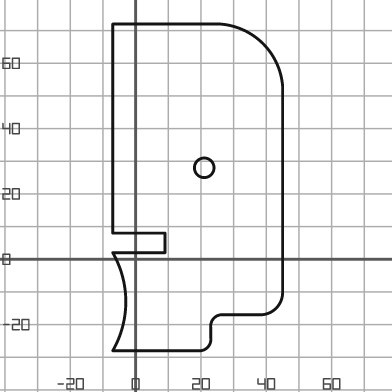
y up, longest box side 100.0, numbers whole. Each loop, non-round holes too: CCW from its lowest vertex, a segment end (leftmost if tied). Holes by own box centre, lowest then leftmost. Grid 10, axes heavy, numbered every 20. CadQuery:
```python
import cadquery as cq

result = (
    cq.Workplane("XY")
    .moveTo(-7.0, -28.0)
    .lineTo(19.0, -28.0)
    .threePointArc((22.0, -27.0), (23.0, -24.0))
    .lineTo(23.0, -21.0)
    .threePointArc((24.0, -18.0), (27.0, -17.0))
    .lineTo(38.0, -17.0)
    .threePointArc((43.0, -15.0), (45.0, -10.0))
    .lineTo(45.0, 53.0)
    .threePointArc((39.0, 66.0), (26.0, 72.0))
    .lineTo(-7.0, 72.0)
    .lineTo(-7.0, 8.0)
    .lineTo(9.0, 8.0)
    .lineTo(9.0, 2.0)
    .lineTo(-7.0, 2.0)
    .threePointArc((-3.0, -13.0), (-7.0, -28.0))
    .close()
    .moveTo(21.0, 28.0)
    .circle(3.0)
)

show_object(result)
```